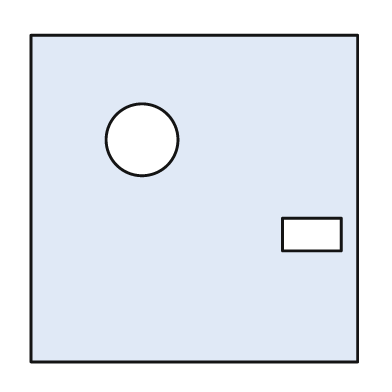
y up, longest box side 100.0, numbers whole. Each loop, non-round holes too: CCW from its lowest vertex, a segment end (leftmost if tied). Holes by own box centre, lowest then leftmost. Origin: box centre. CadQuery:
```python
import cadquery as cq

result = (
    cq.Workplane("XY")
    .moveTo(-50.0, -50.0)
    .lineTo(50.0, -50.0)
    .lineTo(50.0, 50.0)
    .lineTo(-50.0, 50.0)
    .close()
    .moveTo(27.0, -16.0)
    .lineTo(45.0, -16.0)
    .lineTo(45.0, -6.0)
    .lineTo(27.0, -6.0)
    .close()
    .moveTo(-16.0, 18.0)
    .circle(11.0)
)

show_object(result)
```